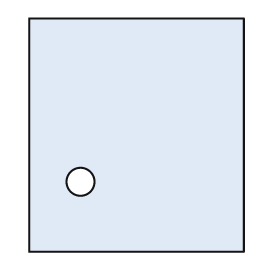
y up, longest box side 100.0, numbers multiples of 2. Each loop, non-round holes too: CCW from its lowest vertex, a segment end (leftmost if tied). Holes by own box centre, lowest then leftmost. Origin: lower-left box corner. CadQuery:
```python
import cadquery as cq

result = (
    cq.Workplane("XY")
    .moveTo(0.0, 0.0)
    .lineTo(92.0, 0.0)
    .lineTo(92.0, 100.0)
    .lineTo(0.0, 100.0)
    .close()
    .moveTo(22.0, 30.0)
    .circle(6.0)
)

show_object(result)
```